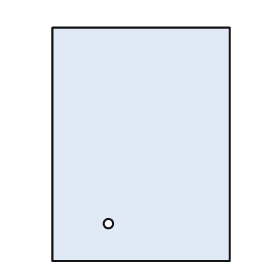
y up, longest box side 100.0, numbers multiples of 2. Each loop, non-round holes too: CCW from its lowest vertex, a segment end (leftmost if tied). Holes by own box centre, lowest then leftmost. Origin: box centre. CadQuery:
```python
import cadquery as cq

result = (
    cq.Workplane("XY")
    .moveTo(-38.0, -50.0)
    .lineTo(38.0, -50.0)
    .lineTo(38.0, 50.0)
    .lineTo(-38.0, 50.0)
    .close()
    .moveTo(-14.0, -34.0)
    .circle(2.0)
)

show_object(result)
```